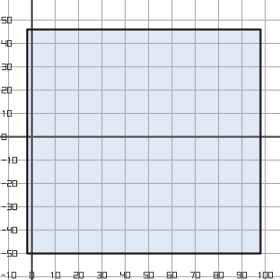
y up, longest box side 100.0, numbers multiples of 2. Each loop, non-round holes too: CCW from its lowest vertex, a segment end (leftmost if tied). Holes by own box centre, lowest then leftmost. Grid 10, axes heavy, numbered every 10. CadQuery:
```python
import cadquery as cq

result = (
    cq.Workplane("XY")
    .moveTo(-2.0, -50.0)
    .lineTo(98.0, -50.0)
    .lineTo(98.0, 46.0)
    .lineTo(-2.0, 46.0)
    .close()
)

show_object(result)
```